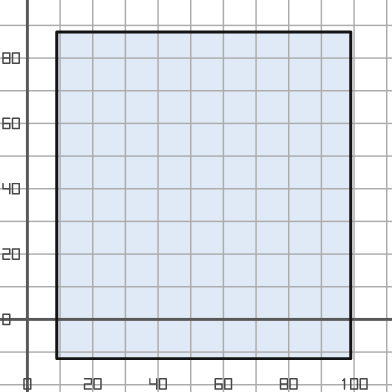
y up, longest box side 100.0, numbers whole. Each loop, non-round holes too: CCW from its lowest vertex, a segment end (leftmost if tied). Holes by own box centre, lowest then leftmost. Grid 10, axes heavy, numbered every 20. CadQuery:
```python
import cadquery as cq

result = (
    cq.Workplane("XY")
    .moveTo(9.0, -12.0)
    .lineTo(99.0, -12.0)
    .lineTo(99.0, 88.0)
    .lineTo(9.0, 88.0)
    .close()
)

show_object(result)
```